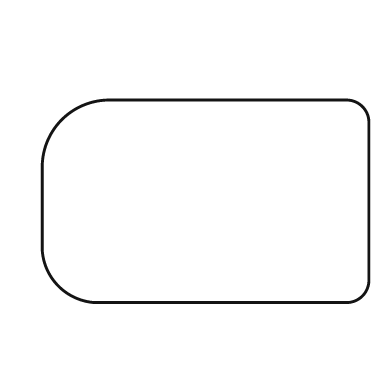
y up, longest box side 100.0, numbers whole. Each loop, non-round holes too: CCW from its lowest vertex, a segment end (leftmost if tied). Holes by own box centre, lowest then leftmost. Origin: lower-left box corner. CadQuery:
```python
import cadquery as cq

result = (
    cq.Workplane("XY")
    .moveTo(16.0, 0.0)
    .lineTo(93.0, 0.0)
    .threePointArc((98.0, 2.0), (100.0, 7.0))
    .lineTo(100.0, 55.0)
    .threePointArc((98.0, 60.0), (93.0, 62.0))
    .lineTo(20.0, 62.0)
    .threePointArc((6.0, 56.0), (0.0, 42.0))
    .lineTo(0.0, 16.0)
    .threePointArc((5.0, 5.0), (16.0, 0.0))
    .close()
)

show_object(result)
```